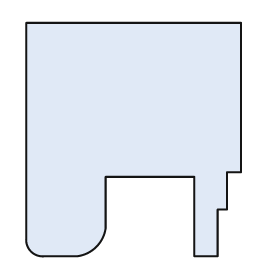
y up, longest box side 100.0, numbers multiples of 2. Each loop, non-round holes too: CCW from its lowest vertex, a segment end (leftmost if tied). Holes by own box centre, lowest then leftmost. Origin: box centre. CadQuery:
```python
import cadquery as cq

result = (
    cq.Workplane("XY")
    .moveTo(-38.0, -50.0)
    .lineTo(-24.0, -50.0)
    .threePointArc((-16.0, -46.0), (-12.0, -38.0))
    .lineTo(-12.0, -16.0)
    .lineTo(26.0, -16.0)
    .lineTo(26.0, -50.0)
    .lineTo(36.0, -50.0)
    .lineTo(36.0, -30.0)
    .lineTo(40.0, -30.0)
    .lineTo(40.0, -14.0)
    .lineTo(46.0, -14.0)
    .lineTo(46.0, 50.0)
    .lineTo(-46.0, 50.0)
    .lineTo(-46.0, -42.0)
    .threePointArc((-44.0, -48.0), (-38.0, -50.0))
    .close()
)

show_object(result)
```